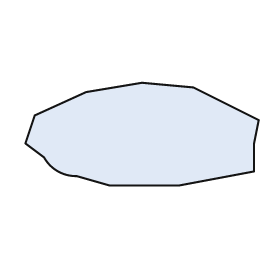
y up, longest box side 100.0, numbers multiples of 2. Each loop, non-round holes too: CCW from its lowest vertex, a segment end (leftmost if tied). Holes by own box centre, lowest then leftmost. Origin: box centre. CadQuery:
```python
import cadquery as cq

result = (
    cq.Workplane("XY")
    .moveTo(-14.0, -22.0)
    .lineTo(16.0, -22.0)
    .lineTo(48.0, -16.0)
    .lineTo(48.0, -4.0)
    .lineTo(50.0, 6.0)
    .lineTo(22.0, 20.0)
    .lineTo(0.0, 22.0)
    .lineTo(-24.0, 18.0)
    .lineTo(-46.0, 8.0)
    .lineTo(-50.0, -4.0)
    .lineTo(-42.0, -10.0)
    .threePointArc((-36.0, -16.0), (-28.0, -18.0))
    .close()
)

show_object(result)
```